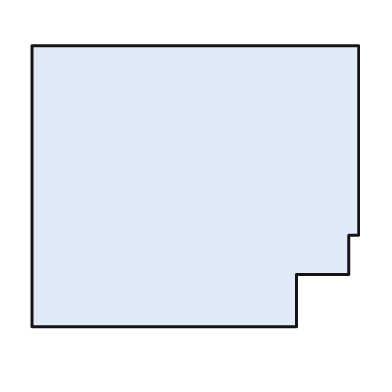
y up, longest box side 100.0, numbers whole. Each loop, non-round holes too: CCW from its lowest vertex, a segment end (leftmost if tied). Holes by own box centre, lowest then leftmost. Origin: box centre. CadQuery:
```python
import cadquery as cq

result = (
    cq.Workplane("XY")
    .moveTo(-50.0, -43.0)
    .lineTo(31.0, -43.0)
    .lineTo(31.0, -27.0)
    .lineTo(47.0, -27.0)
    .lineTo(47.0, -15.0)
    .lineTo(50.0, -15.0)
    .lineTo(50.0, 43.0)
    .lineTo(-50.0, 43.0)
    .close()
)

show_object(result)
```